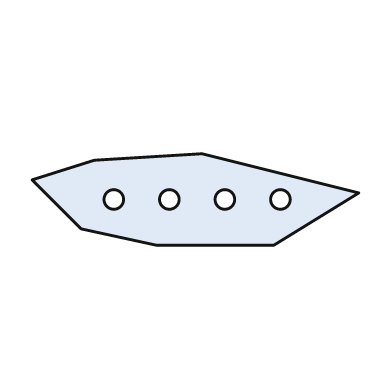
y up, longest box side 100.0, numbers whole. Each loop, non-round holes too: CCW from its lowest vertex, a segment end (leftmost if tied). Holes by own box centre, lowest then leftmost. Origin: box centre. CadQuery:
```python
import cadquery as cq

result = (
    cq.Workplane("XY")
    .moveTo(-12.0, -14.0)
    .lineTo(24.0, -14.0)
    .lineTo(50.0, 2.0)
    .lineTo(2.0, 14.0)
    .lineTo(-31.0, 12.0)
    .lineTo(-50.0, 6.0)
    .lineTo(-35.0, -9.0)
    .close()
    .moveTo(-25.0, 0.0)
    .circle(3.0)
    .moveTo(-8.0, 0.0)
    .circle(3.0)
    .moveTo(9.0, 0.0)
    .circle(3.0)
    .moveTo(26.0, 0.0)
    .circle(3.0)
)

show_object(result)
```